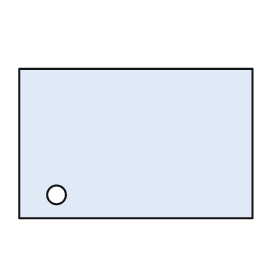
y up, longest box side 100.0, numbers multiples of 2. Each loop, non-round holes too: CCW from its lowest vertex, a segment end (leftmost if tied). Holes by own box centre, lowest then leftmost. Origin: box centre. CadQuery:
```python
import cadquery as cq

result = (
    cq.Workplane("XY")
    .moveTo(-50.0, -32.0)
    .lineTo(50.0, -32.0)
    .lineTo(50.0, 32.0)
    .lineTo(-50.0, 32.0)
    .close()
    .moveTo(-34.0, -22.0)
    .circle(4.0)
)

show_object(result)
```